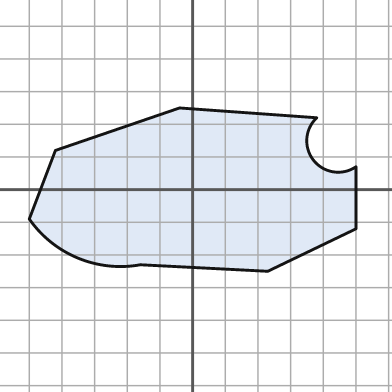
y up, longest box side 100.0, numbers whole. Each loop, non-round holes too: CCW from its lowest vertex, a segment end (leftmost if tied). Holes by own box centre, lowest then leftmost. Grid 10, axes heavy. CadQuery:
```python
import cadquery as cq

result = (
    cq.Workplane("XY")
    .moveTo(23.0, -25.0)
    .lineTo(50.0, -12.0)
    .lineTo(50.0, 7.0)
    .threePointArc((37.0, 9.0), (38.0, 22.0))
    .lineTo(-4.0, 25.0)
    .lineTo(-42.0, 12.0)
    .lineTo(-50.0, -9.0)
    .threePointArc((-35.0, -21.0), (-16.0, -23.0))
    .close()
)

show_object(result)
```